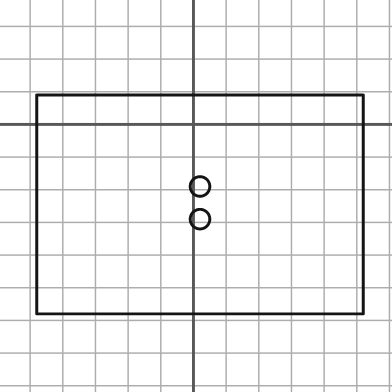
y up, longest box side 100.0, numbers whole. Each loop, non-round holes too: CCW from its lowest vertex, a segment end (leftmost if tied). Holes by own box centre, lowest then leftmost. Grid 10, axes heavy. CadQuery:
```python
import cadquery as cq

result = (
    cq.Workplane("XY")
    .moveTo(-48.0, -58.0)
    .lineTo(52.0, -58.0)
    .lineTo(52.0, 9.0)
    .lineTo(-48.0, 9.0)
    .close()
    .moveTo(2.0, -29.0)
    .circle(3.0)
    .moveTo(2.0, -19.0)
    .circle(3.0)
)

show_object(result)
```